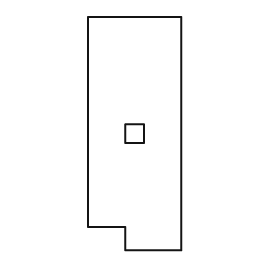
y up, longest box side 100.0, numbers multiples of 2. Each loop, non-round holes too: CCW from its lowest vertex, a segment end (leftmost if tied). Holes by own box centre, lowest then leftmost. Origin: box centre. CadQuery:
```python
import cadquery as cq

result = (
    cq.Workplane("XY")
    .moveTo(-4.0, -50.0)
    .lineTo(20.0, -50.0)
    .lineTo(20.0, 50.0)
    .lineTo(-20.0, 50.0)
    .lineTo(-20.0, -40.0)
    .lineTo(-4.0, -40.0)
    .close()
    .moveTo(-4.0, -4.0)
    .lineTo(4.0, -4.0)
    .lineTo(4.0, 4.0)
    .lineTo(-4.0, 4.0)
    .close()
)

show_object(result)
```